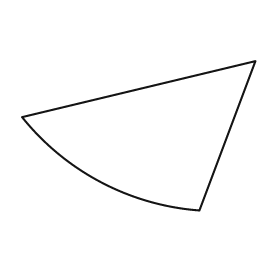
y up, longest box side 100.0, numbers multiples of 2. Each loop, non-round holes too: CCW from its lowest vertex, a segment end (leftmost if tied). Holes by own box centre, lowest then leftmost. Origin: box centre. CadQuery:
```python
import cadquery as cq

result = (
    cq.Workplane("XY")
    .moveTo(26.0, -32.0)
    .lineTo(50.0, 32.0)
    .lineTo(-50.0, 8.0)
    .threePointArc((-16.0, -20.0), (26.0, -32.0))
    .close()
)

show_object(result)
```